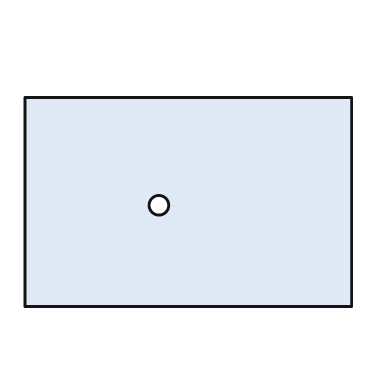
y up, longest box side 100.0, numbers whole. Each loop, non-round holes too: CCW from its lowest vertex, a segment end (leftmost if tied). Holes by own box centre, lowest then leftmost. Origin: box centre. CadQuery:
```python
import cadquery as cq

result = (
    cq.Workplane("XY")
    .moveTo(-50.0, -32.0)
    .lineTo(50.0, -32.0)
    .lineTo(50.0, 32.0)
    .lineTo(-50.0, 32.0)
    .close()
    .moveTo(-9.0, -1.0)
    .circle(3.0)
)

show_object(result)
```